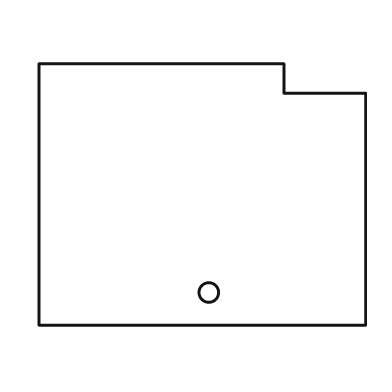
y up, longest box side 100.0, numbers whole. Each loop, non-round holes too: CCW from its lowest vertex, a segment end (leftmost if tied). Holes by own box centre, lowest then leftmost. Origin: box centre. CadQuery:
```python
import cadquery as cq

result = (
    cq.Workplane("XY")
    .moveTo(-50.0, -40.0)
    .lineTo(50.0, -40.0)
    .lineTo(50.0, 31.0)
    .lineTo(25.0, 31.0)
    .lineTo(25.0, 40.0)
    .lineTo(-50.0, 40.0)
    .close()
    .moveTo(2.0, -30.0)
    .circle(3.0)
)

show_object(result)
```